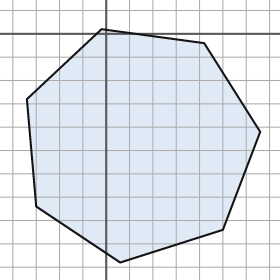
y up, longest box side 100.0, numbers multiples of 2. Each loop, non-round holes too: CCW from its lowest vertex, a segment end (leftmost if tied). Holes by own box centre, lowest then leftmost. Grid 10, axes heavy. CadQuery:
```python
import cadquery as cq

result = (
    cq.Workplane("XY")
    .moveTo(6.0, -98.0)
    .lineTo(50.0, -84.0)
    .lineTo(66.0, -42.0)
    .lineTo(42.0, -4.0)
    .lineTo(-2.0, 2.0)
    .lineTo(-34.0, -28.0)
    .lineTo(-30.0, -74.0)
    .close()
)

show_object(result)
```